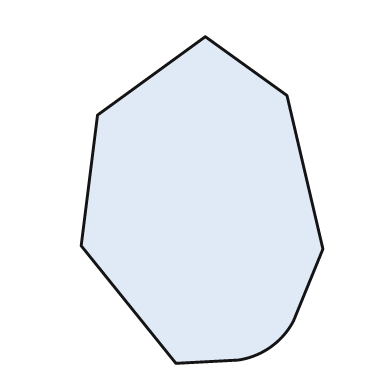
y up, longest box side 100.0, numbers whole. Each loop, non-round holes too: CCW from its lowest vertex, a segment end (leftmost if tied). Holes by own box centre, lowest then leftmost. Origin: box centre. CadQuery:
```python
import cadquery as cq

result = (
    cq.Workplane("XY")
    .moveTo(-8.0, -50.0)
    .lineTo(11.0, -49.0)
    .threePointArc((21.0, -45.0), (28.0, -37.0))
    .lineTo(37.0, -15.0)
    .lineTo(26.0, 32.0)
    .lineTo(1.0, 50.0)
    .lineTo(-32.0, 26.0)
    .lineTo(-37.0, -14.0)
    .close()
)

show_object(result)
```